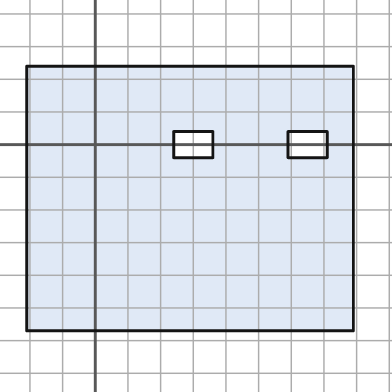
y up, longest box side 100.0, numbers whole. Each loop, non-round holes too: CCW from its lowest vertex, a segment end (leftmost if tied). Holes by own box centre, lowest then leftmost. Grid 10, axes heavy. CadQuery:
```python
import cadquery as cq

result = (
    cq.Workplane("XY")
    .moveTo(-21.0, -57.0)
    .lineTo(79.0, -57.0)
    .lineTo(79.0, 24.0)
    .lineTo(-21.0, 24.0)
    .close()
    .moveTo(24.0, -4.0)
    .lineTo(36.0, -4.0)
    .lineTo(36.0, 4.0)
    .lineTo(24.0, 4.0)
    .close()
    .moveTo(59.0, -4.0)
    .lineTo(71.0, -4.0)
    .lineTo(71.0, 4.0)
    .lineTo(59.0, 4.0)
    .close()
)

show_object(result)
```